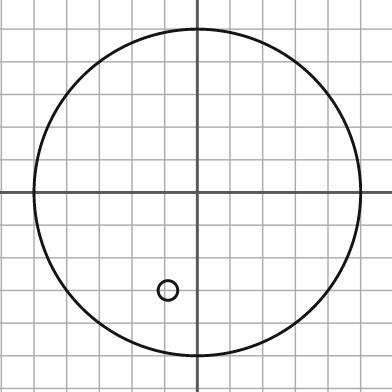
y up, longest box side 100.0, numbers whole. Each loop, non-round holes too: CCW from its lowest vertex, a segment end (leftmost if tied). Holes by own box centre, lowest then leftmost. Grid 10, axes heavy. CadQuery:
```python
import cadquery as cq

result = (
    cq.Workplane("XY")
    .moveTo(0.0, 0.0)
    .circle(50.0)
    .moveTo(-9.0, -30.0)
    .circle(3.0)
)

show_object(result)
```